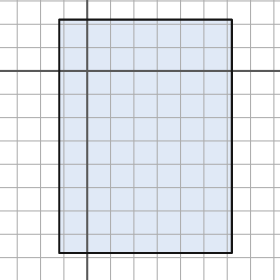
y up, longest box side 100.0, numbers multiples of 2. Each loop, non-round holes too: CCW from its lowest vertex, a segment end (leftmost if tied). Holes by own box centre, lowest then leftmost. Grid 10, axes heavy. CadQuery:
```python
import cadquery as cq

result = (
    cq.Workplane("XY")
    .moveTo(-12.0, -78.0)
    .lineTo(62.0, -78.0)
    .lineTo(62.0, 22.0)
    .lineTo(-12.0, 22.0)
    .close()
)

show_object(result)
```